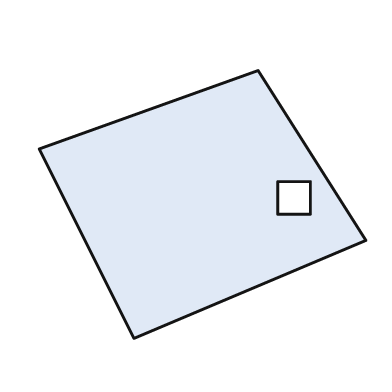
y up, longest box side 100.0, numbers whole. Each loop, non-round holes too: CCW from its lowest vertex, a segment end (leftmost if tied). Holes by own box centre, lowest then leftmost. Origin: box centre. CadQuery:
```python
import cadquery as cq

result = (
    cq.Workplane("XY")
    .moveTo(-21.0, -41.0)
    .lineTo(50.0, -11.0)
    .lineTo(17.0, 41.0)
    .lineTo(-50.0, 17.0)
    .close()
    .moveTo(23.0, -3.0)
    .lineTo(33.0, -3.0)
    .lineTo(33.0, 7.0)
    .lineTo(23.0, 7.0)
    .close()
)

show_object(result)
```